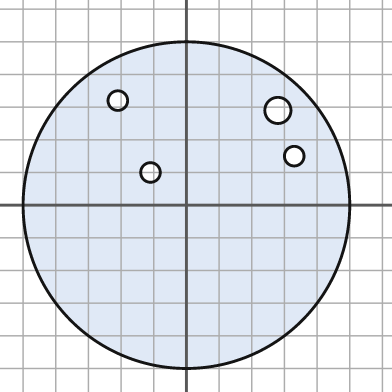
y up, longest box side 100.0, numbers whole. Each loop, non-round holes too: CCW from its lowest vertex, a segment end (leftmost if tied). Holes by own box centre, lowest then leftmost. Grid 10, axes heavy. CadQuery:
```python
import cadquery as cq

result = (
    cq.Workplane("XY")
    .moveTo(0.0, 0.0)
    .circle(50.0)
    .moveTo(-11.0, 10.0)
    .circle(3.0)
    .moveTo(33.0, 15.0)
    .circle(3.0)
    .moveTo(28.0, 29.0)
    .circle(4.0)
    .moveTo(-21.0, 32.0)
    .circle(3.0)
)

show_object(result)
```